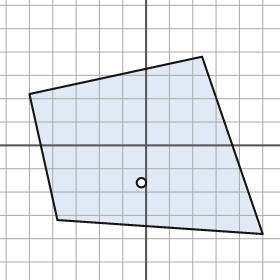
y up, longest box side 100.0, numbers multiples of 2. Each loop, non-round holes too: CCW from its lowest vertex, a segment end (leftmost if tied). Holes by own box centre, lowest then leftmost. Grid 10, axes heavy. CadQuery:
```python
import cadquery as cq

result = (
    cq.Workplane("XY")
    .moveTo(50.0, -38.0)
    .lineTo(24.0, 38.0)
    .lineTo(-50.0, 22.0)
    .lineTo(-38.0, -32.0)
    .close()
    .moveTo(-2.0, -16.0)
    .circle(2.0)
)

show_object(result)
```